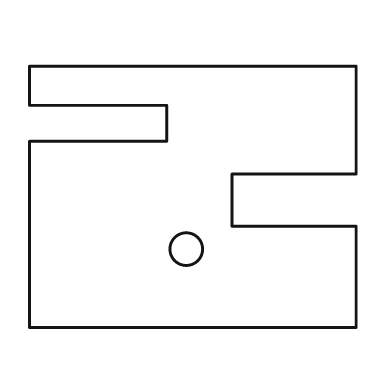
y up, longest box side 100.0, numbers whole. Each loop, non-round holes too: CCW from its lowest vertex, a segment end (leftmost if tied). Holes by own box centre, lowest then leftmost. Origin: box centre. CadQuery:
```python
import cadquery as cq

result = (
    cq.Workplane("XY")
    .moveTo(-50.0, -40.0)
    .lineTo(50.0, -40.0)
    .lineTo(50.0, -9.0)
    .lineTo(12.0, -9.0)
    .lineTo(12.0, 7.0)
    .lineTo(50.0, 7.0)
    .lineTo(50.0, 40.0)
    .lineTo(-50.0, 40.0)
    .lineTo(-50.0, 28.0)
    .lineTo(-8.0, 28.0)
    .lineTo(-8.0, 17.0)
    .lineTo(-50.0, 17.0)
    .close()
    .moveTo(-2.0, -16.0)
    .circle(5.0)
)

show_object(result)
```